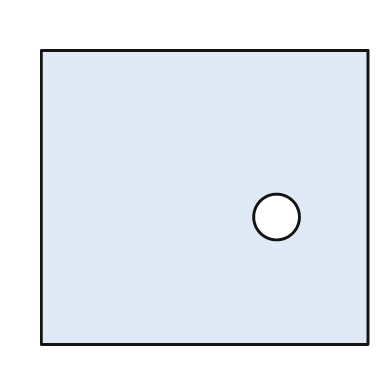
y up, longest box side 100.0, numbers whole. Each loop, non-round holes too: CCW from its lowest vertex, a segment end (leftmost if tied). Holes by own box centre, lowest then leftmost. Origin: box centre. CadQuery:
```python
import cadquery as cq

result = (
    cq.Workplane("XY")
    .moveTo(-50.0, -45.0)
    .lineTo(50.0, -45.0)
    .lineTo(50.0, 45.0)
    .lineTo(-50.0, 45.0)
    .close()
    .moveTo(22.0, -6.0)
    .circle(7.0)
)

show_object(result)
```